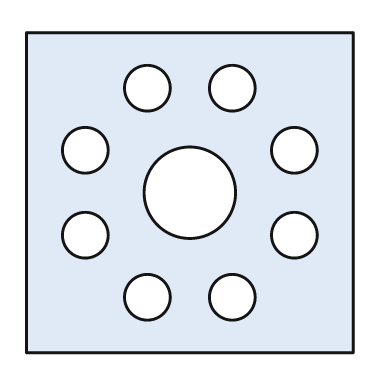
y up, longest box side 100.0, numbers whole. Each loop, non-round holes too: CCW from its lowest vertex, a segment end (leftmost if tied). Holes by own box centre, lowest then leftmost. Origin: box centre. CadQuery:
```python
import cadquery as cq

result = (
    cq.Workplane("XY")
    .moveTo(-50.0, -49.0)
    .lineTo(50.0, -49.0)
    .lineTo(50.0, 49.0)
    .lineTo(-50.0, 49.0)
    .close()
    .moveTo(-13.0, -32.0)
    .circle(7.0)
    .moveTo(13.0, -32.0)
    .circle(7.0)
    .moveTo(-32.0, -13.0)
    .circle(7.0)
    .moveTo(32.0, -13.0)
    .circle(7.0)
    .moveTo(0.0, 0.0)
    .circle(14.0)
    .moveTo(-32.0, 13.0)
    .circle(7.0)
    .moveTo(32.0, 13.0)
    .circle(7.0)
    .moveTo(-13.0, 32.0)
    .circle(7.0)
    .moveTo(13.0, 32.0)
    .circle(7.0)
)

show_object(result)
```